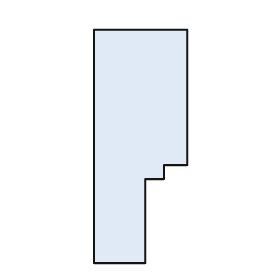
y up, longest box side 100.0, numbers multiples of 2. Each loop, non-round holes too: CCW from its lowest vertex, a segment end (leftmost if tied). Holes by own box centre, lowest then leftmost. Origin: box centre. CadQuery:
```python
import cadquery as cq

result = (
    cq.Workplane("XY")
    .moveTo(-20.0, -50.0)
    .lineTo(2.0, -50.0)
    .lineTo(2.0, -14.0)
    .lineTo(10.0, -14.0)
    .lineTo(10.0, -8.0)
    .lineTo(20.0, -8.0)
    .lineTo(20.0, 50.0)
    .lineTo(-20.0, 50.0)
    .close()
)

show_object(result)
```